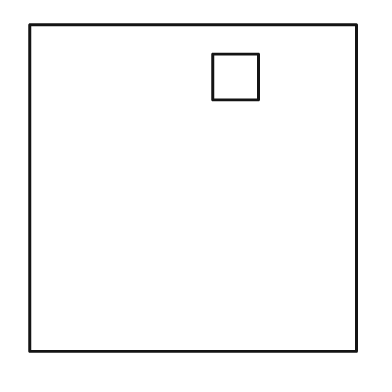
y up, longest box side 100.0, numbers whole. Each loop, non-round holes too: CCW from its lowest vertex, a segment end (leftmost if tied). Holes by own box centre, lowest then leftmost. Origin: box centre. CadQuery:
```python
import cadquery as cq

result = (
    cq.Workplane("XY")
    .moveTo(-50.0, -50.0)
    .lineTo(50.0, -50.0)
    .lineTo(50.0, 50.0)
    .lineTo(-50.0, 50.0)
    .close()
    .moveTo(6.0, 27.0)
    .lineTo(20.0, 27.0)
    .lineTo(20.0, 41.0)
    .lineTo(6.0, 41.0)
    .close()
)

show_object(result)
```